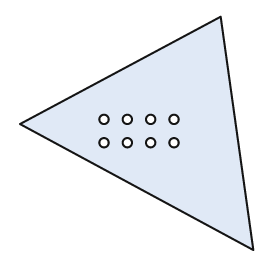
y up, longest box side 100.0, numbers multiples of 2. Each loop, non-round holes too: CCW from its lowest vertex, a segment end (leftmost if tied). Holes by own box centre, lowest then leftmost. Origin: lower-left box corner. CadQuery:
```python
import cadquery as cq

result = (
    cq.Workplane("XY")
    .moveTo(100.0, 0.0)
    .lineTo(86.0, 100.0)
    .lineTo(0.0, 54.0)
    .close()
    .moveTo(36.0, 46.0)
    .circle(2.0)
    .moveTo(46.0, 46.0)
    .circle(2.0)
    .moveTo(56.0, 46.0)
    .circle(2.0)
    .moveTo(66.0, 46.0)
    .circle(2.0)
    .moveTo(36.0, 56.0)
    .circle(2.0)
    .moveTo(46.0, 56.0)
    .circle(2.0)
    .moveTo(56.0, 56.0)
    .circle(2.0)
    .moveTo(66.0, 56.0)
    .circle(2.0)
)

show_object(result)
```